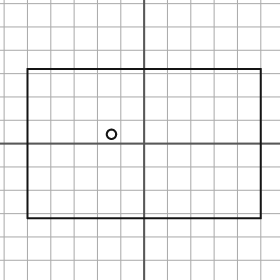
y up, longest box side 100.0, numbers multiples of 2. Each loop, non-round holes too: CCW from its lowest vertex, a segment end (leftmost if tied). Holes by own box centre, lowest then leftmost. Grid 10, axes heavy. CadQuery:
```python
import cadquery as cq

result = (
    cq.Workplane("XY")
    .moveTo(-50.0, -32.0)
    .lineTo(50.0, -32.0)
    .lineTo(50.0, 32.0)
    .lineTo(-50.0, 32.0)
    .close()
    .moveTo(-14.0, 4.0)
    .circle(2.0)
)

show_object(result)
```